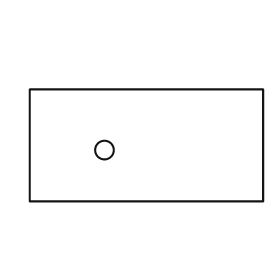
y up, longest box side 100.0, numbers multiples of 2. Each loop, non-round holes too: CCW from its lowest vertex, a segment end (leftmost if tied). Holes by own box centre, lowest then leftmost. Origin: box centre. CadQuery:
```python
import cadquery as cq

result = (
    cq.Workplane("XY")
    .moveTo(-50.0, -24.0)
    .lineTo(50.0, -24.0)
    .lineTo(50.0, 24.0)
    .lineTo(-50.0, 24.0)
    .close()
    .moveTo(-18.0, -2.0)
    .circle(4.0)
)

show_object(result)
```